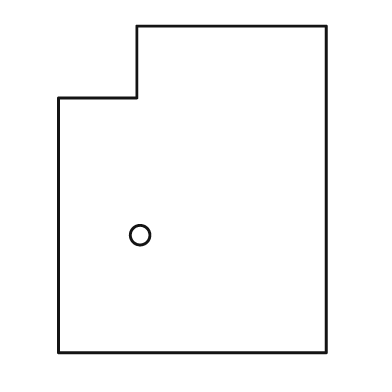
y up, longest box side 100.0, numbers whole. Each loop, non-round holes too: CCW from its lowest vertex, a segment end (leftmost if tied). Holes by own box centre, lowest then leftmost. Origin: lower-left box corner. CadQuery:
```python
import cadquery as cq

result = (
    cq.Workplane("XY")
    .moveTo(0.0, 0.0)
    .lineTo(82.0, 0.0)
    .lineTo(82.0, 100.0)
    .lineTo(24.0, 100.0)
    .lineTo(24.0, 78.0)
    .lineTo(0.0, 78.0)
    .close()
    .moveTo(25.0, 36.0)
    .circle(3.0)
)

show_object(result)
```